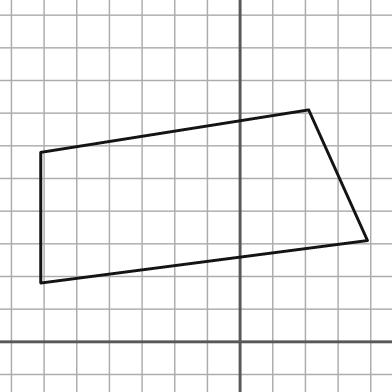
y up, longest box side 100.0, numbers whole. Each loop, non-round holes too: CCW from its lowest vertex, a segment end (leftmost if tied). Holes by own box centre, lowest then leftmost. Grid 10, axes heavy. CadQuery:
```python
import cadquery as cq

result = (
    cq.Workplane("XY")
    .moveTo(-61.0, 18.0)
    .lineTo(39.0, 31.0)
    .lineTo(21.0, 71.0)
    .lineTo(-61.0, 58.0)
    .close()
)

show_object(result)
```